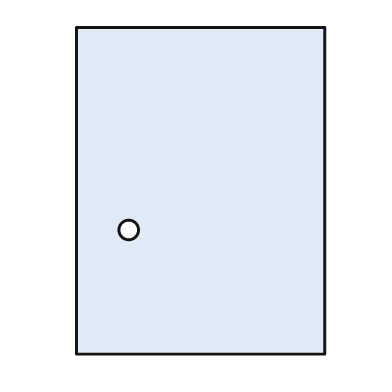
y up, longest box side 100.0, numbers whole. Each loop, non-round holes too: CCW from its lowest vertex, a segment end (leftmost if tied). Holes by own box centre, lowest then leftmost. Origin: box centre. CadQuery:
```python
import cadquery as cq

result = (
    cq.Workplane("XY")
    .moveTo(-38.0, -50.0)
    .lineTo(38.0, -50.0)
    .lineTo(38.0, 50.0)
    .lineTo(-38.0, 50.0)
    .close()
    .moveTo(-22.0, -12.0)
    .circle(3.0)
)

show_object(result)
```